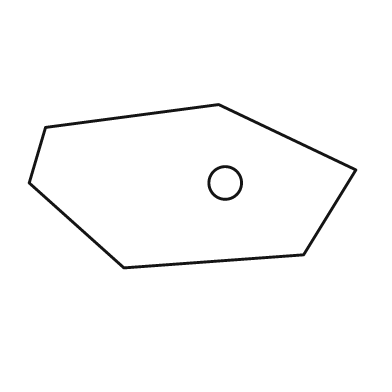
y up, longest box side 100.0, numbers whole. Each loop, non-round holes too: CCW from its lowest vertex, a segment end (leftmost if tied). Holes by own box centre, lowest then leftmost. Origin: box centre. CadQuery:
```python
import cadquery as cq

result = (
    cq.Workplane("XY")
    .moveTo(-21.0, -25.0)
    .lineTo(34.0, -21.0)
    .lineTo(50.0, 5.0)
    .lineTo(8.0, 25.0)
    .lineTo(-45.0, 18.0)
    .lineTo(-50.0, 1.0)
    .close()
    .moveTo(10.0, 1.0)
    .circle(5.0)
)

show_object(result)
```